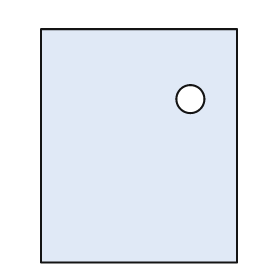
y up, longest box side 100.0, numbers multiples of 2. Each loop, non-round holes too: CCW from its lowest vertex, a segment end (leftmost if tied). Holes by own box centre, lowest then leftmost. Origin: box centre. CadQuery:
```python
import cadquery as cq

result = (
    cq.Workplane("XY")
    .moveTo(-42.0, -50.0)
    .lineTo(42.0, -50.0)
    .lineTo(42.0, 50.0)
    .lineTo(-42.0, 50.0)
    .close()
    .moveTo(22.0, 20.0)
    .circle(6.0)
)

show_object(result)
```